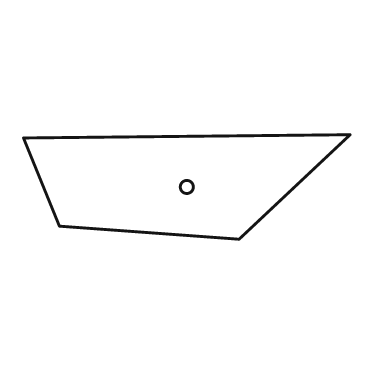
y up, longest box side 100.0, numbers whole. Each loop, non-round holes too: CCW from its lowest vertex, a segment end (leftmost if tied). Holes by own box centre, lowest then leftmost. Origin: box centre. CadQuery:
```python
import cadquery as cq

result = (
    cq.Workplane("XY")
    .moveTo(16.0, -16.0)
    .lineTo(50.0, 16.0)
    .lineTo(-50.0, 15.0)
    .lineTo(-39.0, -12.0)
    .close()
    .moveTo(0.0, 0.0)
    .circle(2.0)
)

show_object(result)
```